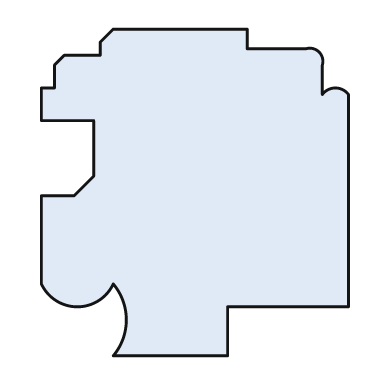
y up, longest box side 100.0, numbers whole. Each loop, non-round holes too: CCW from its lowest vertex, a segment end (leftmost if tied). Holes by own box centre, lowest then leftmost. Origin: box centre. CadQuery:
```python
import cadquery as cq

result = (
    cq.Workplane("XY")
    .moveTo(-25.0, -50.0)
    .lineTo(10.0, -50.0)
    .lineTo(10.0, -35.0)
    .lineTo(47.0, -35.0)
    .lineTo(47.0, 30.0)
    .threePointArc((43.0, 32.0), (39.0, 30.0))
    .lineTo(39.0, 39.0)
    .threePointArc((38.0, 43.0), (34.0, 44.0))
    .lineTo(16.0, 44.0)
    .lineTo(16.0, 50.0)
    .lineTo(-25.0, 50.0)
    .lineTo(-29.0, 46.0)
    .lineTo(-29.0, 42.0)
    .lineTo(-40.0, 42.0)
    .lineTo(-43.0, 39.0)
    .lineTo(-43.0, 32.0)
    .lineTo(-47.0, 32.0)
    .lineTo(-47.0, 22.0)
    .lineTo(-31.0, 22.0)
    .lineTo(-31.0, 5.0)
    .lineTo(-37.0, -1.0)
    .lineTo(-47.0, -1.0)
    .lineTo(-47.0, -28.0)
    .threePointArc((-36.0, -35.0), (-25.0, -28.0))
    .threePointArc((-21.0, -39.0), (-25.0, -50.0))
    .close()
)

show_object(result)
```